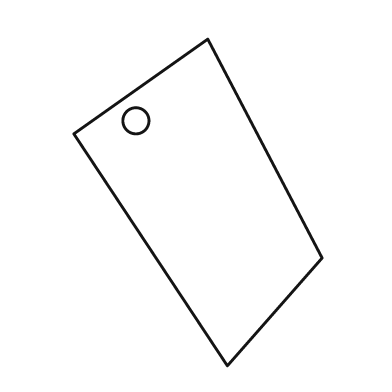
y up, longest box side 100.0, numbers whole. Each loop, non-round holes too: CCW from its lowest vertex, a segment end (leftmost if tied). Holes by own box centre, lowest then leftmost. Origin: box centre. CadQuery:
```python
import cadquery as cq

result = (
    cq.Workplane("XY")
    .moveTo(9.0, -50.0)
    .lineTo(38.0, -17.0)
    .lineTo(3.0, 50.0)
    .lineTo(-38.0, 21.0)
    .close()
    .moveTo(-19.0, 25.0)
    .circle(4.0)
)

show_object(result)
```